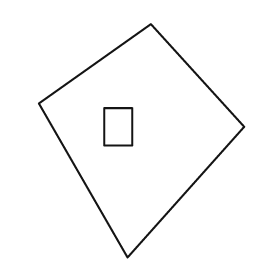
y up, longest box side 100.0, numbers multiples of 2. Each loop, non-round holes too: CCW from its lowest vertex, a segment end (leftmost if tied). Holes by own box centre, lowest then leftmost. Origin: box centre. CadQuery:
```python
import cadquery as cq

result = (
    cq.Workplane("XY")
    .moveTo(-6.0, -50.0)
    .lineTo(44.0, 6.0)
    .lineTo(4.0, 50.0)
    .lineTo(-44.0, 16.0)
    .close()
    .moveTo(-16.0, -2.0)
    .lineTo(-4.0, -2.0)
    .lineTo(-4.0, 14.0)
    .lineTo(-16.0, 14.0)
    .close()
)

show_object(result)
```